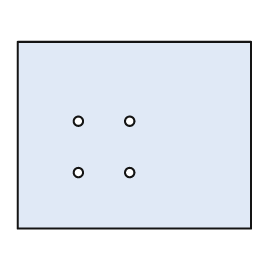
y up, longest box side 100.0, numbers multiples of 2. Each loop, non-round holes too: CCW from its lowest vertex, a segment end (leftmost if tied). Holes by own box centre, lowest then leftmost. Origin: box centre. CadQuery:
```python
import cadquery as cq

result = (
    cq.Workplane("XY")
    .moveTo(-50.0, -40.0)
    .lineTo(50.0, -40.0)
    .lineTo(50.0, 40.0)
    .lineTo(-50.0, 40.0)
    .close()
    .moveTo(-24.0, -16.0)
    .circle(2.0)
    .moveTo(-2.0, -16.0)
    .circle(2.0)
    .moveTo(-24.0, 6.0)
    .circle(2.0)
    .moveTo(-2.0, 6.0)
    .circle(2.0)
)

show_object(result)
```